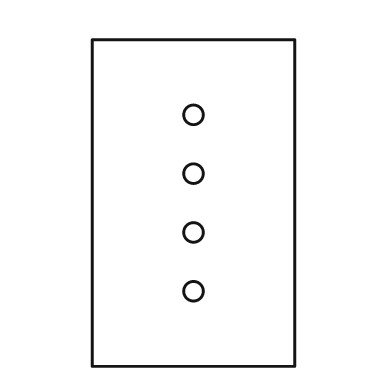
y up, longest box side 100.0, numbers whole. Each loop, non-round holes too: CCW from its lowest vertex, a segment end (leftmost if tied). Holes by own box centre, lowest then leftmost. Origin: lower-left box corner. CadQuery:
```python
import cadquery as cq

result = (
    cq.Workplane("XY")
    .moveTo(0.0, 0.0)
    .lineTo(62.0, 0.0)
    .lineTo(62.0, 100.0)
    .lineTo(0.0, 100.0)
    .close()
    .moveTo(31.0, 23.0)
    .circle(3.0)
    .moveTo(31.0, 41.0)
    .circle(3.0)
    .moveTo(31.0, 59.0)
    .circle(3.0)
    .moveTo(31.0, 77.0)
    .circle(3.0)
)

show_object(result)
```